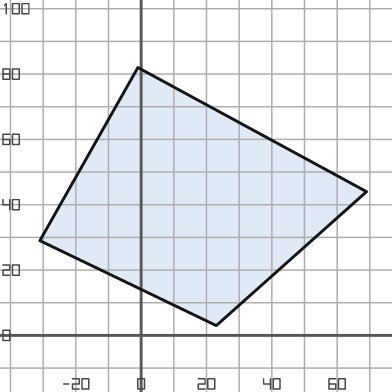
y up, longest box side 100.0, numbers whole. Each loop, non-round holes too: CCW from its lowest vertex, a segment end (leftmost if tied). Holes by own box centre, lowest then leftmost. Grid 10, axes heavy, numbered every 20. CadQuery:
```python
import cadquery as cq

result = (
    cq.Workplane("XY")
    .moveTo(23.0, 3.0)
    .lineTo(69.0, 44.0)
    .lineTo(-1.0, 82.0)
    .lineTo(-31.0, 29.0)
    .close()
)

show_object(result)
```